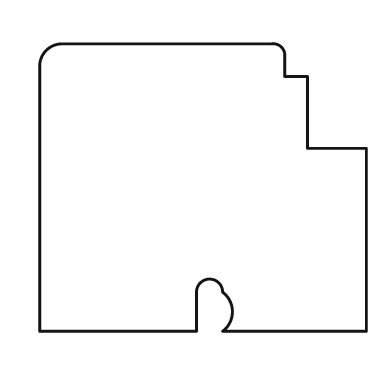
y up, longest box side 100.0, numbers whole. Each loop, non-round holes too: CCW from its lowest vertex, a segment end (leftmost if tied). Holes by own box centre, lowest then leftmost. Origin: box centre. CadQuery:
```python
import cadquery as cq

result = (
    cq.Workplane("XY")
    .moveTo(-50.0, -44.0)
    .lineTo(-2.0, -44.0)
    .lineTo(-2.0, -32.0)
    .threePointArc((2.0, -28.0), (6.0, -32.0))
    .threePointArc((9.0, -38.0), (6.0, -44.0))
    .lineTo(50.0, -44.0)
    .lineTo(50.0, 12.0)
    .lineTo(32.0, 12.0)
    .lineTo(32.0, 34.0)
    .lineTo(25.0, 34.0)
    .lineTo(25.0, 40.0)
    .threePointArc((24.0, 43.0), (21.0, 44.0))
    .lineTo(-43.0, 44.0)
    .threePointArc((-48.0, 42.0), (-50.0, 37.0))
    .close()
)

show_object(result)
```